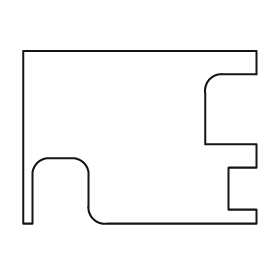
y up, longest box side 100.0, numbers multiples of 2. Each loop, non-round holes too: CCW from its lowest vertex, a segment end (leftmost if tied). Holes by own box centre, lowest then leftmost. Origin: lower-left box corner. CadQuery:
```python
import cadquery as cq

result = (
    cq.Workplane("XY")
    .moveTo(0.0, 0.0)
    .lineTo(4.0, 0.0)
    .lineTo(4.0, 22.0)
    .threePointArc((6.0, 26.0), (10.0, 28.0))
    .lineTo(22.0, 28.0)
    .threePointArc((26.0, 26.0), (28.0, 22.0))
    .lineTo(28.0, 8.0)
    .threePointArc((30.0, 2.0), (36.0, 0.0))
    .lineTo(100.0, 0.0)
    .lineTo(100.0, 6.0)
    .lineTo(88.0, 6.0)
    .lineTo(88.0, 24.0)
    .lineTo(100.0, 24.0)
    .lineTo(100.0, 34.0)
    .lineTo(78.0, 34.0)
    .lineTo(78.0, 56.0)
    .threePointArc((80.0, 62.0), (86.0, 64.0))
    .lineTo(100.0, 64.0)
    .lineTo(100.0, 74.0)
    .lineTo(0.0, 74.0)
    .close()
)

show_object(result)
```